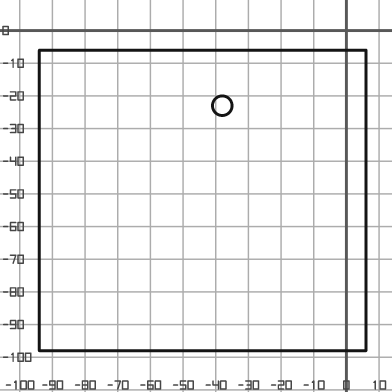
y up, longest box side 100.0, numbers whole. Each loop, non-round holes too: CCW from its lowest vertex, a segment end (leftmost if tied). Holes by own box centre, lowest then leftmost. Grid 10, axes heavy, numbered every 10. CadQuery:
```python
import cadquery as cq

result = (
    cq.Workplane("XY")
    .moveTo(-94.0, -98.0)
    .lineTo(6.0, -98.0)
    .lineTo(6.0, -6.0)
    .lineTo(-94.0, -6.0)
    .close()
    .moveTo(-38.0, -23.0)
    .circle(3.0)
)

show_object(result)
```